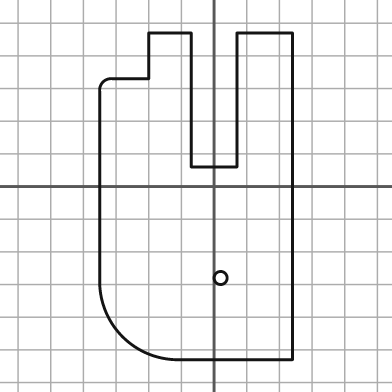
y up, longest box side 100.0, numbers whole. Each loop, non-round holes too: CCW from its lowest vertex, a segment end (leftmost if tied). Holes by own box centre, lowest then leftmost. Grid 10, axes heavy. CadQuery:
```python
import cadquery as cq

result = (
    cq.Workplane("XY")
    .moveTo(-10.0, -53.0)
    .lineTo(24.0, -53.0)
    .lineTo(24.0, 47.0)
    .lineTo(7.0, 47.0)
    .lineTo(7.0, 6.0)
    .lineTo(-7.0, 6.0)
    .lineTo(-7.0, 47.0)
    .lineTo(-20.0, 47.0)
    .lineTo(-20.0, 33.0)
    .lineTo(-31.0, 33.0)
    .threePointArc((-34.0, 32.0), (-35.0, 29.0))
    .lineTo(-35.0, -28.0)
    .threePointArc((-28.0, -46.0), (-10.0, -53.0))
    .close()
    .moveTo(2.0, -28.0)
    .circle(2.0)
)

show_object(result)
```